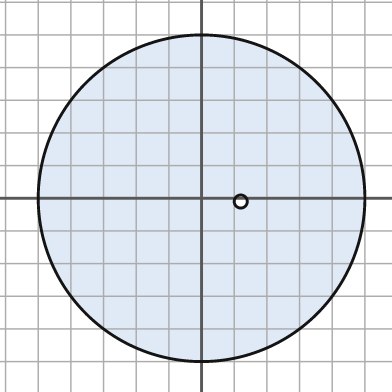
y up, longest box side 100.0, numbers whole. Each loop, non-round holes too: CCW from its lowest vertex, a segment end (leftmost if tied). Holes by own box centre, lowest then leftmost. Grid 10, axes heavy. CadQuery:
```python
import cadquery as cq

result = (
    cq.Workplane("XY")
    .moveTo(0.0, 0.0)
    .circle(50.0)
    .moveTo(12.0, -1.0)
    .circle(2.0)
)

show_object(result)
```